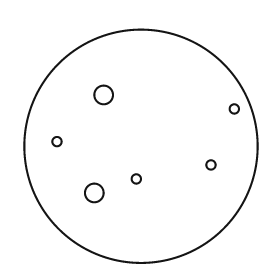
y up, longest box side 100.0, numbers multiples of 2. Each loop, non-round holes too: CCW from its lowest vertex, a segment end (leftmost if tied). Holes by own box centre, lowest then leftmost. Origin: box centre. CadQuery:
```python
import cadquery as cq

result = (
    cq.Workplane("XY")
    .moveTo(0.0, 0.0)
    .circle(50.0)
    .moveTo(-20.0, -20.0)
    .circle(4.0)
    .moveTo(-2.0, -14.0)
    .circle(2.0)
    .moveTo(30.0, -8.0)
    .circle(2.0)
    .moveTo(-36.0, 2.0)
    .circle(2.0)
    .moveTo(40.0, 16.0)
    .circle(2.0)
    .moveTo(-16.0, 22.0)
    .circle(4.0)
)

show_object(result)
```